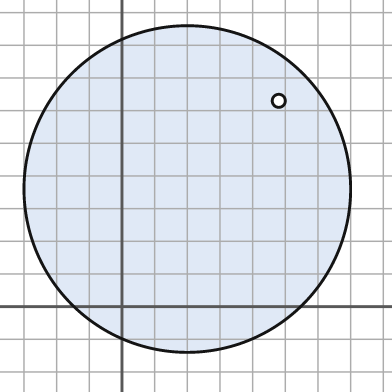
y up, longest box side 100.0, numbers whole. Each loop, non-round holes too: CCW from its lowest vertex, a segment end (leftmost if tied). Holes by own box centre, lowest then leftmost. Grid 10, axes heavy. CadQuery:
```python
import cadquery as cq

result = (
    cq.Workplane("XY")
    .moveTo(20.0, 36.0)
    .circle(50.0)
    .moveTo(48.0, 63.0)
    .circle(2.0)
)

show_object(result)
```